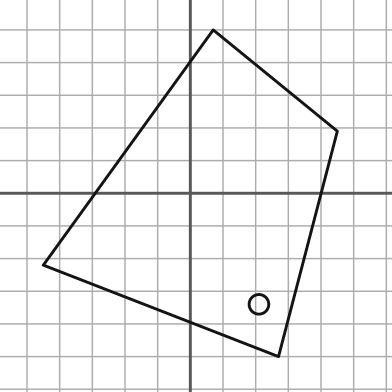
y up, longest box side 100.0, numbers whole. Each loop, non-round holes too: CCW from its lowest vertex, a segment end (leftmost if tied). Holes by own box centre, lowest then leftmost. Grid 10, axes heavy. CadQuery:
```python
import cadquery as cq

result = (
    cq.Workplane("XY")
    .moveTo(27.0, -50.0)
    .lineTo(45.0, 19.0)
    .lineTo(7.0, 50.0)
    .lineTo(-45.0, -22.0)
    .close()
    .moveTo(21.0, -34.0)
    .circle(3.0)
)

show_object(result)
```